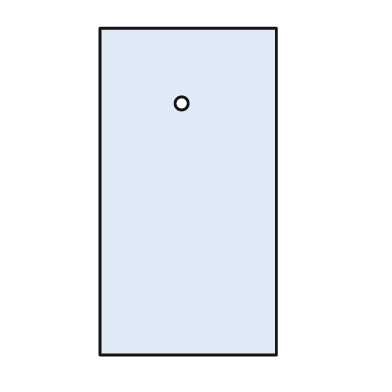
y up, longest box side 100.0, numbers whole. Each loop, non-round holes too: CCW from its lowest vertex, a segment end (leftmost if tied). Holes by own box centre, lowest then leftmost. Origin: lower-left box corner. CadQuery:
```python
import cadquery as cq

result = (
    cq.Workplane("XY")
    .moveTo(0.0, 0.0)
    .lineTo(54.0, 0.0)
    .lineTo(54.0, 100.0)
    .lineTo(0.0, 100.0)
    .close()
    .moveTo(25.0, 77.0)
    .circle(2.0)
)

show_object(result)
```